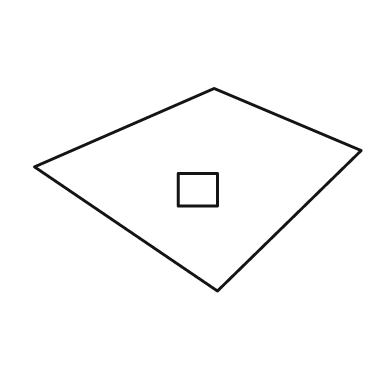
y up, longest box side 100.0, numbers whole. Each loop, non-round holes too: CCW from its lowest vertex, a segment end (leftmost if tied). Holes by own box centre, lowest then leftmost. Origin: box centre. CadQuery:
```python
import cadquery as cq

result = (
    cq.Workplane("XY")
    .moveTo(6.0, -31.0)
    .lineTo(50.0, 12.0)
    .lineTo(5.0, 31.0)
    .lineTo(-50.0, 7.0)
    .close()
    .moveTo(-6.0, -5.0)
    .lineTo(6.0, -5.0)
    .lineTo(6.0, 5.0)
    .lineTo(-6.0, 5.0)
    .close()
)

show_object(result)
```